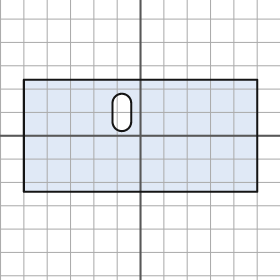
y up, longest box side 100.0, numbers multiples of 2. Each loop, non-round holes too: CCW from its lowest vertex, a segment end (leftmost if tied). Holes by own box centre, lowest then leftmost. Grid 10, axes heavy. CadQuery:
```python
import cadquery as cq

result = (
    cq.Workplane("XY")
    .moveTo(-50.0, -24.0)
    .lineTo(50.0, -24.0)
    .lineTo(50.0, 24.0)
    .lineTo(-50.0, 24.0)
    .close()
    .moveTo(-12.0, 6.0)
    .threePointArc((-8.0, 2.0), (-4.0, 6.0))
    .lineTo(-4.0, 14.0)
    .threePointArc((-8.0, 18.0), (-12.0, 14.0))
    .close()
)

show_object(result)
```